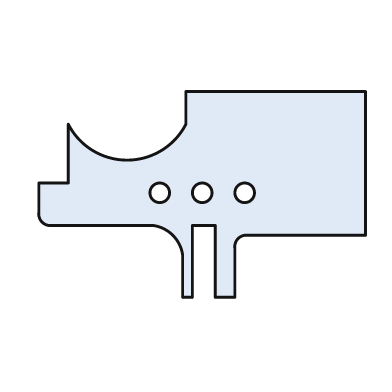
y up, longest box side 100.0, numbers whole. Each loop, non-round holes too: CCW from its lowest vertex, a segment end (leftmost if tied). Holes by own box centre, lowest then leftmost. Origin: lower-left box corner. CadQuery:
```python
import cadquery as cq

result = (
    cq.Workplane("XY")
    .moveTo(44.0, 0.0)
    .lineTo(47.0, 0.0)
    .lineTo(47.0, 22.0)
    .lineTo(54.0, 22.0)
    .lineTo(54.0, 0.0)
    .lineTo(60.0, 0.0)
    .lineTo(60.0, 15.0)
    .threePointArc((61.0, 18.0), (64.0, 19.0))
    .lineTo(100.0, 19.0)
    .lineTo(100.0, 63.0)
    .lineTo(45.0, 63.0)
    .lineTo(45.0, 53.0)
    .threePointArc((27.0, 42.0), (9.0, 53.0))
    .lineTo(9.0, 35.0)
    .lineTo(0.0, 35.0)
    .lineTo(0.0, 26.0)
    .threePointArc((1.0, 23.0), (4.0, 22.0))
    .lineTo(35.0, 22.0)
    .threePointArc((41.0, 19.0), (44.0, 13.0))
    .close()
    .moveTo(37.0, 32.0)
    .circle(3.0)
    .moveTo(50.0, 32.0)
    .circle(3.0)
    .moveTo(63.0, 32.0)
    .circle(3.0)
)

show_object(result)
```